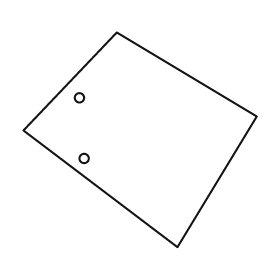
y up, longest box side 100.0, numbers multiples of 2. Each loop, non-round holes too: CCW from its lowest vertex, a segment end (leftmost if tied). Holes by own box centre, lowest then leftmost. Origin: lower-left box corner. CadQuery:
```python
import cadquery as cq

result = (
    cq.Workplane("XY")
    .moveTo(66.0, 0.0)
    .lineTo(100.0, 56.0)
    .lineTo(40.0, 92.0)
    .lineTo(0.0, 50.0)
    .close()
    .moveTo(26.0, 38.0)
    .circle(2.0)
    .moveTo(24.0, 64.0)
    .circle(2.0)
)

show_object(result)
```